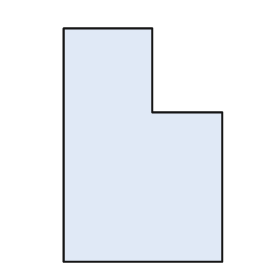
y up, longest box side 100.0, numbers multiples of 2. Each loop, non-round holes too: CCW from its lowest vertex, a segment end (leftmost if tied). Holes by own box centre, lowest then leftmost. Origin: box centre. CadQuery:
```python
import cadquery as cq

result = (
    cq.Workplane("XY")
    .moveTo(-34.0, -50.0)
    .lineTo(34.0, -50.0)
    .lineTo(34.0, 14.0)
    .lineTo(4.0, 14.0)
    .lineTo(4.0, 50.0)
    .lineTo(-34.0, 50.0)
    .close()
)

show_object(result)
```